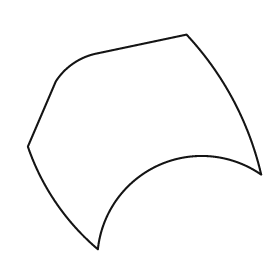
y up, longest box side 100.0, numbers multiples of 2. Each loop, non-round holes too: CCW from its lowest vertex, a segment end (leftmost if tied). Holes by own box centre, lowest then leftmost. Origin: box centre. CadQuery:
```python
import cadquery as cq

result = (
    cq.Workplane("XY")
    .moveTo(-20.0, -46.0)
    .threePointArc((6.0, -10.0), (50.0, -14.0))
    .threePointArc((38.0, 18.0), (18.0, 46.0))
    .lineTo(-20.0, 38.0)
    .threePointArc((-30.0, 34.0), (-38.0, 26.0))
    .lineTo(-50.0, -2.0)
    .threePointArc((-38.0, -26.0), (-20.0, -46.0))
    .close()
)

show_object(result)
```